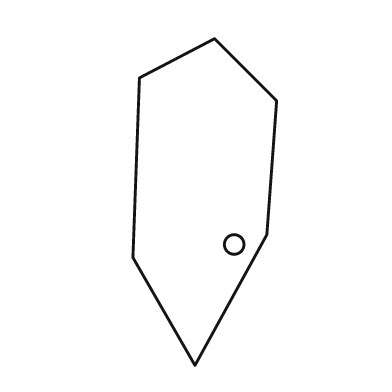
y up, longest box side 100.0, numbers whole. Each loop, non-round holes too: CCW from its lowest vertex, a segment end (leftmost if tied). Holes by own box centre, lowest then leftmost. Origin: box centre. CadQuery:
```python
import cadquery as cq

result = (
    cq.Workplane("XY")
    .moveTo(-3.0, -50.0)
    .lineTo(19.0, -10.0)
    .lineTo(22.0, 31.0)
    .lineTo(3.0, 50.0)
    .lineTo(-20.0, 38.0)
    .lineTo(-22.0, -17.0)
    .close()
    .moveTo(9.0, -13.0)
    .circle(3.0)
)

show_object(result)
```